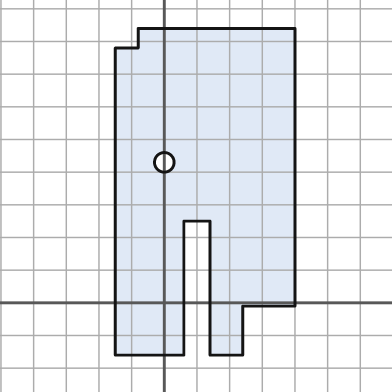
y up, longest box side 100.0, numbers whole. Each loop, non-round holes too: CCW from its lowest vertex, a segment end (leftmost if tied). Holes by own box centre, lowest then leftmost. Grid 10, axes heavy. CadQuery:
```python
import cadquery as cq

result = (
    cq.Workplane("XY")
    .moveTo(-15.0, -16.0)
    .lineTo(6.0, -16.0)
    .lineTo(6.0, 25.0)
    .lineTo(14.0, 25.0)
    .lineTo(14.0, -16.0)
    .lineTo(24.0, -16.0)
    .lineTo(24.0, -1.0)
    .lineTo(40.0, -1.0)
    .lineTo(40.0, 84.0)
    .lineTo(-8.0, 84.0)
    .lineTo(-8.0, 78.0)
    .lineTo(-15.0, 78.0)
    .close()
    .moveTo(0.0, 43.0)
    .circle(3.0)
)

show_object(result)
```